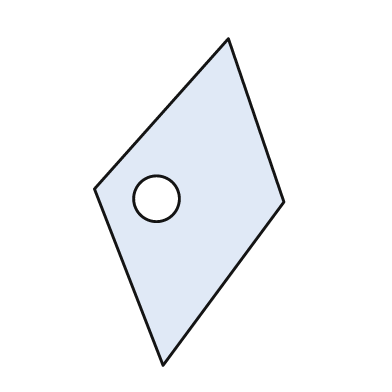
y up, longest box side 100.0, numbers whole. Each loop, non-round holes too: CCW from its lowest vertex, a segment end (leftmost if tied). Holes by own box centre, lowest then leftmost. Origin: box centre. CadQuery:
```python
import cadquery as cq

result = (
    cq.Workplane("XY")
    .moveTo(-8.0, -50.0)
    .lineTo(29.0, 0.0)
    .lineTo(12.0, 50.0)
    .lineTo(-29.0, 4.0)
    .close()
    .moveTo(-10.0, 1.0)
    .circle(7.0)
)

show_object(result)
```